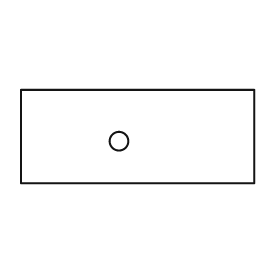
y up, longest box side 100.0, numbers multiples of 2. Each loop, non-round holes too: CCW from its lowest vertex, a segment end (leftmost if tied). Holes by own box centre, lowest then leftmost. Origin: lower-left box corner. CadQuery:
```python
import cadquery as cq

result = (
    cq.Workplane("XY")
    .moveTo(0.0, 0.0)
    .lineTo(100.0, 0.0)
    .lineTo(100.0, 40.0)
    .lineTo(0.0, 40.0)
    .close()
    .moveTo(42.0, 18.0)
    .circle(4.0)
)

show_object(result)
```